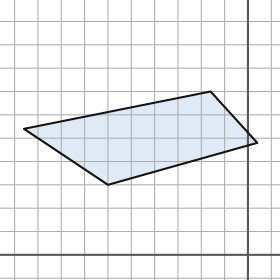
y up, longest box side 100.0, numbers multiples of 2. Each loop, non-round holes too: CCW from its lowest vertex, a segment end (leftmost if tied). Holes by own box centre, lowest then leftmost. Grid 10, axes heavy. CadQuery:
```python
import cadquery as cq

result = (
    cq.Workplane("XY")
    .moveTo(-60.0, 30.0)
    .lineTo(4.0, 48.0)
    .lineTo(-16.0, 70.0)
    .lineTo(-96.0, 54.0)
    .close()
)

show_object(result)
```